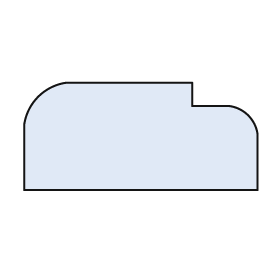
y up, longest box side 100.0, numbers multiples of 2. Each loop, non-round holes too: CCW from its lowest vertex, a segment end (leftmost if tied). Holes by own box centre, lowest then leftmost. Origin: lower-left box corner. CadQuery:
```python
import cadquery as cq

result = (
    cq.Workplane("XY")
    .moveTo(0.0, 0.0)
    .lineTo(100.0, 0.0)
    .lineTo(100.0, 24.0)
    .threePointArc((96.0, 32.0), (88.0, 36.0))
    .lineTo(72.0, 36.0)
    .lineTo(72.0, 46.0)
    .lineTo(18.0, 46.0)
    .threePointArc((6.0, 40.0), (0.0, 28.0))
    .close()
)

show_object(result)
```